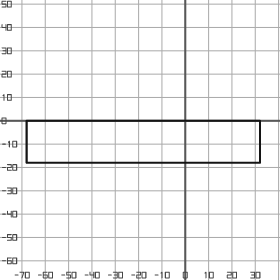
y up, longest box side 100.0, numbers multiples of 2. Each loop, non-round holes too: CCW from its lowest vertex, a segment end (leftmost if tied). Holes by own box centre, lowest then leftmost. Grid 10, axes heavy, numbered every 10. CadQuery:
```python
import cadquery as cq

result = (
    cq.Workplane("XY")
    .moveTo(-68.0, -18.0)
    .lineTo(32.0, -18.0)
    .lineTo(32.0, 0.0)
    .lineTo(-68.0, 0.0)
    .close()
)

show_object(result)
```